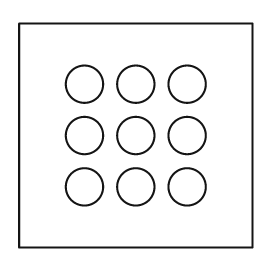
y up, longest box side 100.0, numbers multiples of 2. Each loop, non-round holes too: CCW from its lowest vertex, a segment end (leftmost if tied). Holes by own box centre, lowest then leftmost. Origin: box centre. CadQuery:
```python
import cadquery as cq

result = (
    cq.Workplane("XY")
    .moveTo(-50.0, -48.0)
    .lineTo(50.0, -48.0)
    .lineTo(50.0, 48.0)
    .lineTo(-50.0, 48.0)
    .close()
    .moveTo(-22.0, -22.0)
    .circle(8.0)
    .moveTo(0.0, -22.0)
    .circle(8.0)
    .moveTo(22.0, -22.0)
    .circle(8.0)
    .moveTo(-22.0, 0.0)
    .circle(8.0)
    .moveTo(0.0, 0.0)
    .circle(8.0)
    .moveTo(22.0, 0.0)
    .circle(8.0)
    .moveTo(-22.0, 22.0)
    .circle(8.0)
    .moveTo(0.0, 22.0)
    .circle(8.0)
    .moveTo(22.0, 22.0)
    .circle(8.0)
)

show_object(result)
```